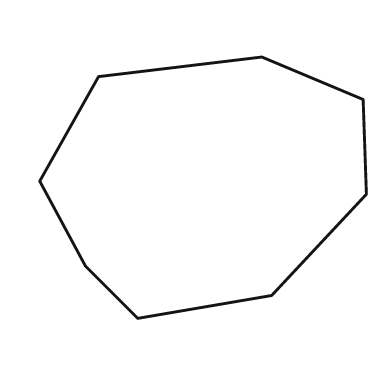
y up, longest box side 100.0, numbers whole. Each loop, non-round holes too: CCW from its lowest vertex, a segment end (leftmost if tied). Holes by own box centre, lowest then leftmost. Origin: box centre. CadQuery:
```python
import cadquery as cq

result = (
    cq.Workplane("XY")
    .moveTo(-20.0, -40.0)
    .lineTo(21.0, -33.0)
    .lineTo(50.0, -2.0)
    .lineTo(49.0, 27.0)
    .lineTo(18.0, 40.0)
    .lineTo(-32.0, 34.0)
    .lineTo(-50.0, 2.0)
    .lineTo(-36.0, -24.0)
    .close()
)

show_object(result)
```